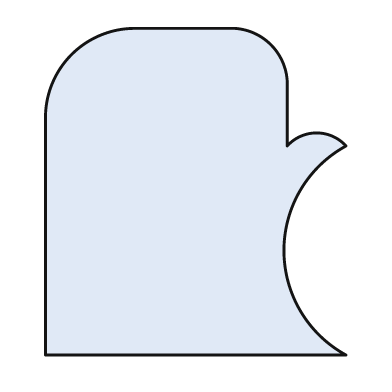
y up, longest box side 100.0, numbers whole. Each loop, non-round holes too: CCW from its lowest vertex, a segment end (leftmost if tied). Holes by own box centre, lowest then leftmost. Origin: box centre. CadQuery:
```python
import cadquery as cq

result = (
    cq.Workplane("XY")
    .moveTo(-46.0, -50.0)
    .lineTo(46.0, -50.0)
    .threePointArc((27.0, -18.0), (46.0, 14.0))
    .threePointArc((37.0, 18.0), (28.0, 14.0))
    .lineTo(28.0, 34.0)
    .threePointArc((23.0, 45.0), (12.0, 50.0))
    .lineTo(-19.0, 50.0)
    .threePointArc((-38.0, 42.0), (-46.0, 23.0))
    .close()
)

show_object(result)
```